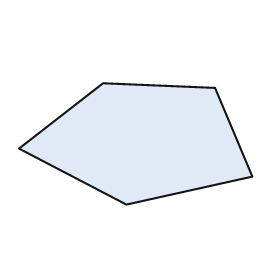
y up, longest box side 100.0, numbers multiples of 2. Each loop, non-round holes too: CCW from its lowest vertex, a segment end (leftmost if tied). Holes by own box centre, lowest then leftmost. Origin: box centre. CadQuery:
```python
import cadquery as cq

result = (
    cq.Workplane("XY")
    .moveTo(-4.0, -26.0)
    .lineTo(50.0, -14.0)
    .lineTo(34.0, 24.0)
    .lineTo(-14.0, 26.0)
    .lineTo(-50.0, -2.0)
    .close()
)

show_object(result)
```